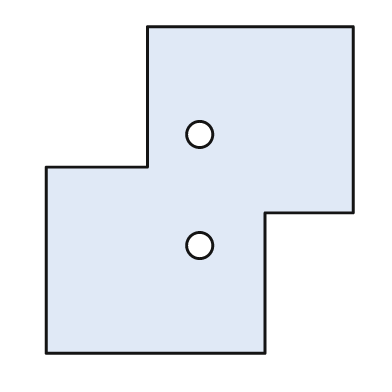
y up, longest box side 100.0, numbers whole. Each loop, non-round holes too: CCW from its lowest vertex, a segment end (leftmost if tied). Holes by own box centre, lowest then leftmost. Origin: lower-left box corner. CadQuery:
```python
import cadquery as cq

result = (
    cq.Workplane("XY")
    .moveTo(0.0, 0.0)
    .lineTo(67.0, 0.0)
    .lineTo(67.0, 43.0)
    .lineTo(94.0, 43.0)
    .lineTo(94.0, 100.0)
    .lineTo(31.0, 100.0)
    .lineTo(31.0, 57.0)
    .lineTo(0.0, 57.0)
    .close()
    .moveTo(47.0, 33.0)
    .circle(4.0)
    .moveTo(47.0, 67.0)
    .circle(4.0)
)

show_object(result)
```